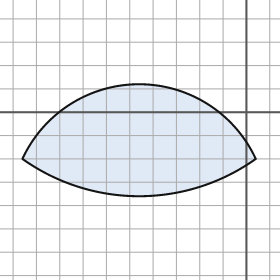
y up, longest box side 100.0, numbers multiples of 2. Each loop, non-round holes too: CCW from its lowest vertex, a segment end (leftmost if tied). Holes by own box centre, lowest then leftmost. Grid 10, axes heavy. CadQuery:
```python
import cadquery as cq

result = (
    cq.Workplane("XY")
    .moveTo(-96.0, -20.0)
    .threePointArc((-46.0, -36.0), (4.0, -20.0))
    .threePointArc((-46.0, 12.0), (-96.0, -20.0))
    .close()
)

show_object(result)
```